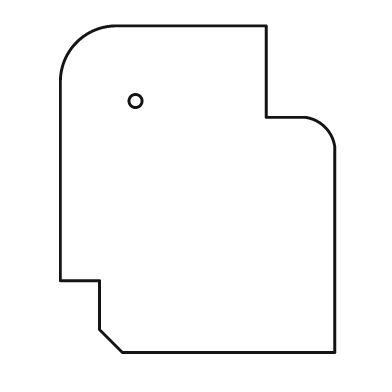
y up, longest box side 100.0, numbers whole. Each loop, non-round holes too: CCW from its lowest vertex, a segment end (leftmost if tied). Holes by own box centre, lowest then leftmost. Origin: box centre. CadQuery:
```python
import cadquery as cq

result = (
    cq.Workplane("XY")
    .moveTo(-23.0, -50.0)
    .lineTo(42.0, -50.0)
    .lineTo(42.0, 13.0)
    .threePointArc((39.0, 19.0), (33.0, 22.0))
    .lineTo(21.0, 22.0)
    .lineTo(21.0, 50.0)
    .lineTo(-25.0, 50.0)
    .threePointArc((-37.0, 45.0), (-42.0, 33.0))
    .lineTo(-42.0, -28.0)
    .lineTo(-30.0, -28.0)
    .lineTo(-30.0, -43.0)
    .close()
    .moveTo(-19.0, 27.0)
    .circle(2.0)
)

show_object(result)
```